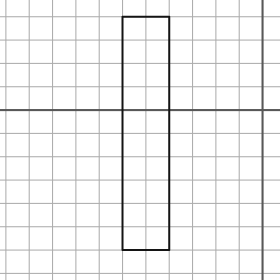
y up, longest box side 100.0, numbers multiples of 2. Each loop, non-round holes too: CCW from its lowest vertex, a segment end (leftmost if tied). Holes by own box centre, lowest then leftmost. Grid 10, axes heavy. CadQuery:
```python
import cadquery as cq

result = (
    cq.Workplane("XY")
    .moveTo(-60.0, -60.0)
    .lineTo(-40.0, -60.0)
    .lineTo(-40.0, 40.0)
    .lineTo(-60.0, 40.0)
    .close()
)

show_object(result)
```